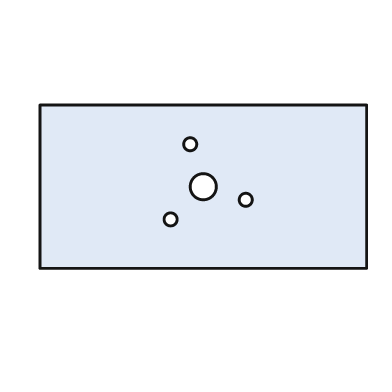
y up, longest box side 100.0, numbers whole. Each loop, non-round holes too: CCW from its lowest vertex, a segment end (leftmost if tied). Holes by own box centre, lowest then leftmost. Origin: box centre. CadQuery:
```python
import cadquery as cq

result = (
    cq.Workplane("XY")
    .moveTo(-50.0, -25.0)
    .lineTo(50.0, -25.0)
    .lineTo(50.0, 25.0)
    .lineTo(-50.0, 25.0)
    .close()
    .moveTo(-10.0, -10.0)
    .circle(2.0)
    .moveTo(13.0, -4.0)
    .circle(2.0)
    .moveTo(0.0, 0.0)
    .circle(4.0)
    .moveTo(-4.0, 13.0)
    .circle(2.0)
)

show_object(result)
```